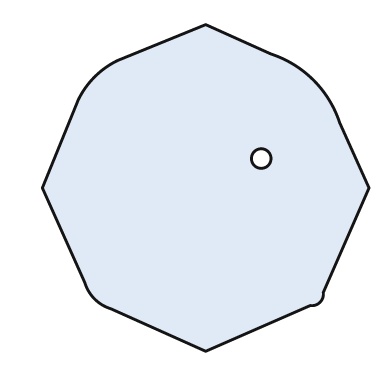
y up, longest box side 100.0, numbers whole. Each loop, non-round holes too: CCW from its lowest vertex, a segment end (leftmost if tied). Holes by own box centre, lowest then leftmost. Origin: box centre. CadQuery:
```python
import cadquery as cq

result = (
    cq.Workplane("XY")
    .moveTo(0.0, -50.0)
    .lineTo(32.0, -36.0)
    .threePointArc((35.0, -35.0), (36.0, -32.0))
    .lineTo(50.0, 0.0)
    .lineTo(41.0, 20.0)
    .threePointArc((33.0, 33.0), (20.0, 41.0))
    .lineTo(0.0, 50.0)
    .lineTo(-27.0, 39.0)
    .threePointArc((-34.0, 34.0), (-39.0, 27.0))
    .lineTo(-50.0, 0.0)
    .lineTo(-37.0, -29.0)
    .threePointArc((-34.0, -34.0), (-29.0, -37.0))
    .close()
    .moveTo(17.0, 9.0)
    .circle(3.0)
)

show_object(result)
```